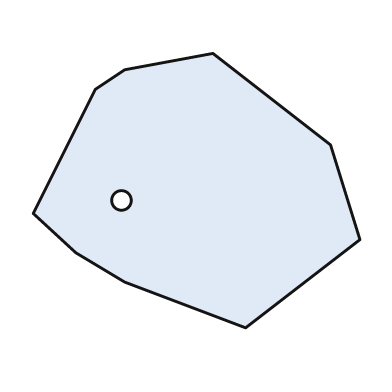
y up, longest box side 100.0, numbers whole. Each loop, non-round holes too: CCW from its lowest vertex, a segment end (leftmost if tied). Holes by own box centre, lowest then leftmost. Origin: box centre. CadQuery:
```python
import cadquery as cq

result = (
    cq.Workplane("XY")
    .moveTo(15.0, -42.0)
    .lineTo(50.0, -15.0)
    .lineTo(41.0, 14.0)
    .lineTo(5.0, 42.0)
    .lineTo(-22.0, 37.0)
    .lineTo(-31.0, 31.0)
    .lineTo(-50.0, -7.0)
    .lineTo(-37.0, -19.0)
    .lineTo(-22.0, -28.0)
    .close()
    .moveTo(-23.0, -3.0)
    .circle(3.0)
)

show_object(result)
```